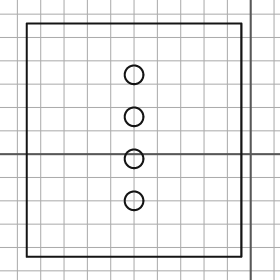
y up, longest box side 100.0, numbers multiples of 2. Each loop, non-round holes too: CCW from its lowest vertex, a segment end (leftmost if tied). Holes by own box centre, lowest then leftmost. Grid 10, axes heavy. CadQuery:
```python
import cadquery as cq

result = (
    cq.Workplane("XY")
    .moveTo(-96.0, -44.0)
    .lineTo(-4.0, -44.0)
    .lineTo(-4.0, 56.0)
    .lineTo(-96.0, 56.0)
    .close()
    .moveTo(-50.0, -20.0)
    .circle(4.0)
    .moveTo(-50.0, -2.0)
    .circle(4.0)
    .moveTo(-50.0, 16.0)
    .circle(4.0)
    .moveTo(-50.0, 34.0)
    .circle(4.0)
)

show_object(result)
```